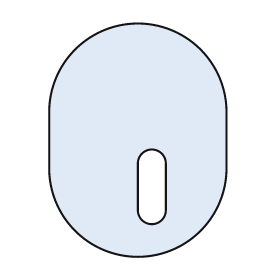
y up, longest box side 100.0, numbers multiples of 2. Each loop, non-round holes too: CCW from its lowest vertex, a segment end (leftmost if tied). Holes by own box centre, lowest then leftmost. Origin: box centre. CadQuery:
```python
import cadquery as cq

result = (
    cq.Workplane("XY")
    .moveTo(-38.0, -12.0)
    .threePointArc((0.0, -50.0), (38.0, -12.0))
    .lineTo(38.0, 12.0)
    .threePointArc((0.0, 50.0), (-38.0, 12.0))
    .close()
    .moveTo(0.0, -30.0)
    .threePointArc((6.0, -36.0), (12.0, -30.0))
    .lineTo(12.0, -10.0)
    .threePointArc((6.0, -4.0), (0.0, -10.0))
    .close()
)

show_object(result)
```